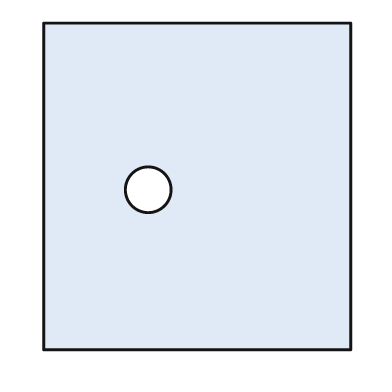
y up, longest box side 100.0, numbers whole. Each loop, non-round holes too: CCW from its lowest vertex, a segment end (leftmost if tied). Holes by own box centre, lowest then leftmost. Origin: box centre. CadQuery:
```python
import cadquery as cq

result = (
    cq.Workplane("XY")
    .moveTo(-47.0, -50.0)
    .lineTo(47.0, -50.0)
    .lineTo(47.0, 50.0)
    .lineTo(-47.0, 50.0)
    .close()
    .moveTo(-15.0, -1.0)
    .circle(7.0)
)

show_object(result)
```